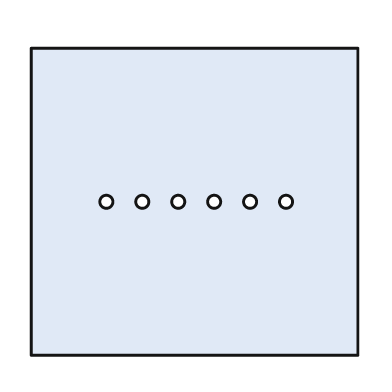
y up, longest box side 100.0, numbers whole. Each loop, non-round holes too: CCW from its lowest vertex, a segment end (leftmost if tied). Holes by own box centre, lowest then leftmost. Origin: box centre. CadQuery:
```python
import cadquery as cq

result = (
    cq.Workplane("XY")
    .moveTo(-50.0, -47.0)
    .lineTo(50.0, -47.0)
    .lineTo(50.0, 47.0)
    .lineTo(-50.0, 47.0)
    .close()
    .moveTo(-27.0, 0.0)
    .circle(2.0)
    .moveTo(-16.0, 0.0)
    .circle(2.0)
    .moveTo(-5.0, 0.0)
    .circle(2.0)
    .moveTo(6.0, 0.0)
    .circle(2.0)
    .moveTo(17.0, 0.0)
    .circle(2.0)
    .moveTo(28.0, 0.0)
    .circle(2.0)
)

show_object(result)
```